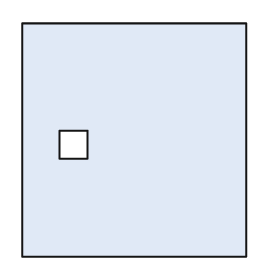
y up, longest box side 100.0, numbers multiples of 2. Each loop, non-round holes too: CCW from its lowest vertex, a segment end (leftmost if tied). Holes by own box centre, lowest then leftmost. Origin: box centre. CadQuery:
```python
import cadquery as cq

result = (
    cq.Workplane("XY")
    .moveTo(-48.0, -50.0)
    .lineTo(48.0, -50.0)
    .lineTo(48.0, 50.0)
    .lineTo(-48.0, 50.0)
    .close()
    .moveTo(-32.0, -8.0)
    .lineTo(-20.0, -8.0)
    .lineTo(-20.0, 4.0)
    .lineTo(-32.0, 4.0)
    .close()
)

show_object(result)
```